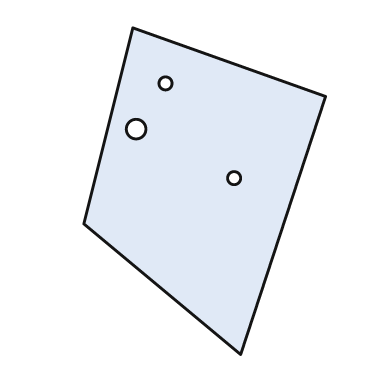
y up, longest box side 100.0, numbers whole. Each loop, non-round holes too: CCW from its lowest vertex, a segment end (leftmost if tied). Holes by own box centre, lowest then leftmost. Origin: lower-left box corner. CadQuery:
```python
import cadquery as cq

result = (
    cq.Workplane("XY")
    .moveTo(48.0, 0.0)
    .lineTo(74.0, 79.0)
    .lineTo(15.0, 100.0)
    .lineTo(0.0, 40.0)
    .close()
    .moveTo(46.0, 54.0)
    .circle(2.0)
    .moveTo(16.0, 69.0)
    .circle(3.0)
    .moveTo(25.0, 83.0)
    .circle(2.0)
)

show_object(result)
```